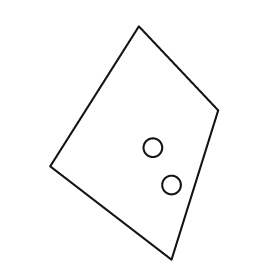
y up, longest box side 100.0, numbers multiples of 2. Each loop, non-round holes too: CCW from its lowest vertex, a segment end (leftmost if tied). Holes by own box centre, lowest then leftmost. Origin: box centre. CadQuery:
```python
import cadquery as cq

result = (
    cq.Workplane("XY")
    .moveTo(16.0, -50.0)
    .lineTo(36.0, 14.0)
    .lineTo(2.0, 50.0)
    .lineTo(-36.0, -10.0)
    .close()
    .moveTo(16.0, -18.0)
    .circle(4.0)
    .moveTo(8.0, -2.0)
    .circle(4.0)
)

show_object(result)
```